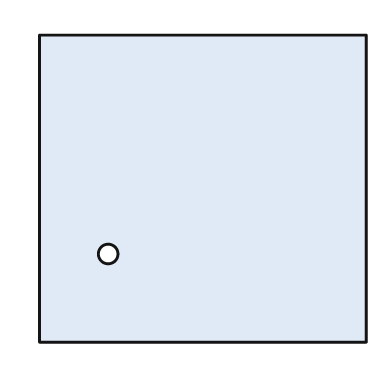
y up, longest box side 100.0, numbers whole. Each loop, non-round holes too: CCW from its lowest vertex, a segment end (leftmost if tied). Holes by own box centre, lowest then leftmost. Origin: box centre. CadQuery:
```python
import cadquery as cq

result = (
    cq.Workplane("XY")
    .moveTo(-50.0, -47.0)
    .lineTo(50.0, -47.0)
    .lineTo(50.0, 47.0)
    .lineTo(-50.0, 47.0)
    .close()
    .moveTo(-29.0, -20.0)
    .circle(3.0)
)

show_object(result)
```